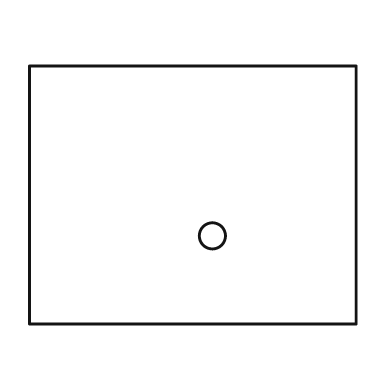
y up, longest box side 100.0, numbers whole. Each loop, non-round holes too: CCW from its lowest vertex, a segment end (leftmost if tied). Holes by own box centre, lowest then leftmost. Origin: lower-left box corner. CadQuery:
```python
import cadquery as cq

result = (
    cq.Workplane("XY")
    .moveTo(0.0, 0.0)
    .lineTo(100.0, 0.0)
    .lineTo(100.0, 79.0)
    .lineTo(0.0, 79.0)
    .close()
    .moveTo(56.0, 27.0)
    .circle(4.0)
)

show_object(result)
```